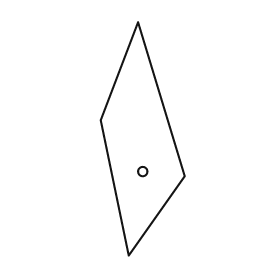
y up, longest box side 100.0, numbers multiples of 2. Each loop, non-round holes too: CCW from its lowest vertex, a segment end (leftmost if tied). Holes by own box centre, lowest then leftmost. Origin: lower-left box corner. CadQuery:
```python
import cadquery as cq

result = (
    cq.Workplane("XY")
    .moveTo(12.0, 0.0)
    .lineTo(36.0, 34.0)
    .lineTo(16.0, 100.0)
    .lineTo(0.0, 58.0)
    .close()
    .moveTo(18.0, 36.0)
    .circle(2.0)
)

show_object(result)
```